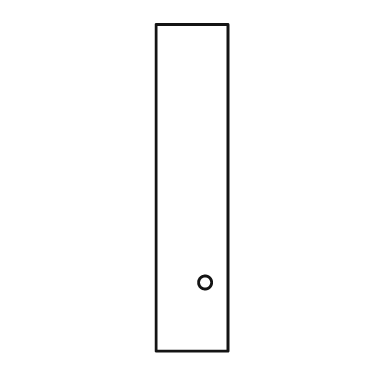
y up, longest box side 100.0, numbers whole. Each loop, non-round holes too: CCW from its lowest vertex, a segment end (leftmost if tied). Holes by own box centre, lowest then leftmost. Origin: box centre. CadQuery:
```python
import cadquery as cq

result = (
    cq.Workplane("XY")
    .moveTo(-11.0, -50.0)
    .lineTo(11.0, -50.0)
    .lineTo(11.0, 50.0)
    .lineTo(-11.0, 50.0)
    .close()
    .moveTo(4.0, -29.0)
    .circle(2.0)
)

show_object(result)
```